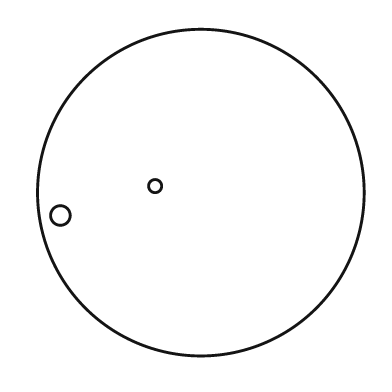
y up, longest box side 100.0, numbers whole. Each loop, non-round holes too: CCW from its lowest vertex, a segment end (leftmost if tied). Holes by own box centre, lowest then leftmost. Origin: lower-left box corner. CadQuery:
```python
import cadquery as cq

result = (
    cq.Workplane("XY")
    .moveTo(50.0, 50.0)
    .circle(50.0)
    .moveTo(7.0, 43.0)
    .circle(3.0)
    .moveTo(36.0, 52.0)
    .circle(2.0)
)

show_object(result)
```